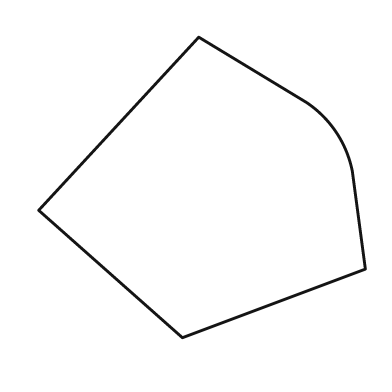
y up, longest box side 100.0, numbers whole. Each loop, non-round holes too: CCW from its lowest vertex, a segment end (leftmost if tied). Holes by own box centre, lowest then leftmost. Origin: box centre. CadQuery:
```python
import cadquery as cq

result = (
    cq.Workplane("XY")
    .moveTo(-6.0, -46.0)
    .lineTo(50.0, -25.0)
    .lineTo(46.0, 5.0)
    .threePointArc((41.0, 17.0), (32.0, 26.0))
    .lineTo(-1.0, 46.0)
    .lineTo(-50.0, -7.0)
    .close()
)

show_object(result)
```